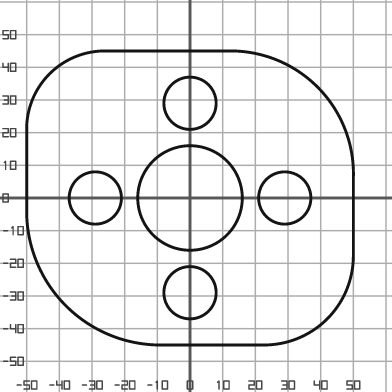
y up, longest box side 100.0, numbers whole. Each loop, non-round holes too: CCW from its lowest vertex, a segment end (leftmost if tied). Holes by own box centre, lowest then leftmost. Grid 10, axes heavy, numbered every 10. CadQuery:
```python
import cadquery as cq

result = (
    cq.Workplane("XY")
    .moveTo(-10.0, -45.0)
    .lineTo(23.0, -45.0)
    .threePointArc((42.0, -37.0), (50.0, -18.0))
    .lineTo(50.0, 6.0)
    .threePointArc((39.0, 34.0), (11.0, 45.0))
    .lineTo(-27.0, 45.0)
    .threePointArc((-43.0, 38.0), (-50.0, 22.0))
    .lineTo(-50.0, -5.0)
    .threePointArc((-38.0, -33.0), (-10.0, -45.0))
    .close()
    .moveTo(0.0, -29.0)
    .circle(8.0)
    .moveTo(-29.0, 0.0)
    .circle(8.0)
    .moveTo(0.0, 0.0)
    .circle(16.0)
    .moveTo(29.0, 0.0)
    .circle(8.0)
    .moveTo(0.0, 29.0)
    .circle(8.0)
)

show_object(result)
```